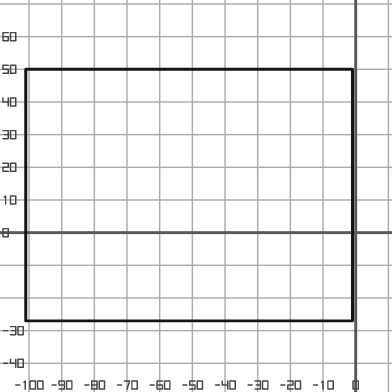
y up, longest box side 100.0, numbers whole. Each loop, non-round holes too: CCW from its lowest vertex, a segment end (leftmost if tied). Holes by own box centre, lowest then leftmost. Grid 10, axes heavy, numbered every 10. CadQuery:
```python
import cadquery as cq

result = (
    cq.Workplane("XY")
    .moveTo(-101.0, -27.0)
    .lineTo(-1.0, -27.0)
    .lineTo(-1.0, 50.0)
    .lineTo(-101.0, 50.0)
    .close()
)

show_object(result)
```